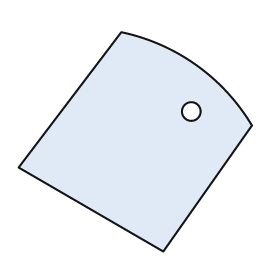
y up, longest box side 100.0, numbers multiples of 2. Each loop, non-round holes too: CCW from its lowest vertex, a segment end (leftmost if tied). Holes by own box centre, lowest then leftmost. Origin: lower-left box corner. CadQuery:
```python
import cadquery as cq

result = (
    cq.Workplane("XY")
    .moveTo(62.0, 0.0)
    .lineTo(100.0, 54.0)
    .threePointArc((76.0, 80.0), (44.0, 94.0))
    .lineTo(0.0, 36.0)
    .close()
    .moveTo(74.0, 60.0)
    .circle(4.0)
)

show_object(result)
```